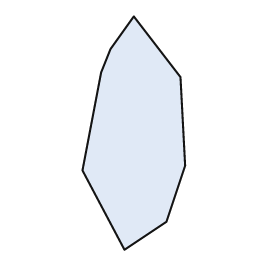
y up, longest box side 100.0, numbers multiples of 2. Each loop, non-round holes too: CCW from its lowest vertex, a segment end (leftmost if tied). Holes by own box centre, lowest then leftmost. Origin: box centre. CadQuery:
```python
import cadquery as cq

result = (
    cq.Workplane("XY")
    .moveTo(-4.0, -50.0)
    .lineTo(14.0, -38.0)
    .lineTo(22.0, -14.0)
    .lineTo(20.0, 24.0)
    .lineTo(0.0, 50.0)
    .lineTo(-10.0, 36.0)
    .lineTo(-14.0, 26.0)
    .lineTo(-22.0, -16.0)
    .close()
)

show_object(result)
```